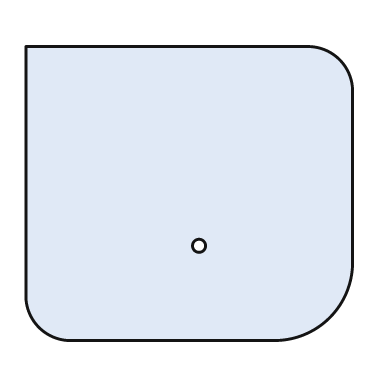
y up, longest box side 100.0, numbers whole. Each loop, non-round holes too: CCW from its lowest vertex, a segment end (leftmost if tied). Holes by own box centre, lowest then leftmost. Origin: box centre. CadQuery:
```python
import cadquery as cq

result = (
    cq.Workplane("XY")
    .moveTo(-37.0, -45.0)
    .lineTo(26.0, -45.0)
    .threePointArc((43.0, -38.0), (50.0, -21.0))
    .lineTo(50.0, 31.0)
    .threePointArc((46.0, 41.0), (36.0, 45.0))
    .lineTo(-50.0, 45.0)
    .lineTo(-50.0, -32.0)
    .threePointArc((-46.0, -41.0), (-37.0, -45.0))
    .close()
    .moveTo(3.0, -16.0)
    .circle(2.0)
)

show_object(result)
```